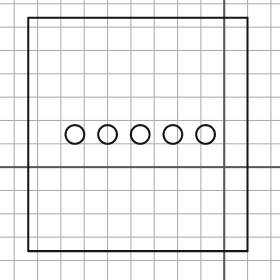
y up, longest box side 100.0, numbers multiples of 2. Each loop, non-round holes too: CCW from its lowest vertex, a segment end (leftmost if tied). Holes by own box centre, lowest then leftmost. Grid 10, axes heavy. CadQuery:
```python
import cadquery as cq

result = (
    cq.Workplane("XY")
    .moveTo(-84.0, -36.0)
    .lineTo(10.0, -36.0)
    .lineTo(10.0, 64.0)
    .lineTo(-84.0, 64.0)
    .close()
    .moveTo(-64.0, 14.0)
    .circle(4.0)
    .moveTo(-50.0, 14.0)
    .circle(4.0)
    .moveTo(-36.0, 14.0)
    .circle(4.0)
    .moveTo(-22.0, 14.0)
    .circle(4.0)
    .moveTo(-8.0, 14.0)
    .circle(4.0)
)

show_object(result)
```